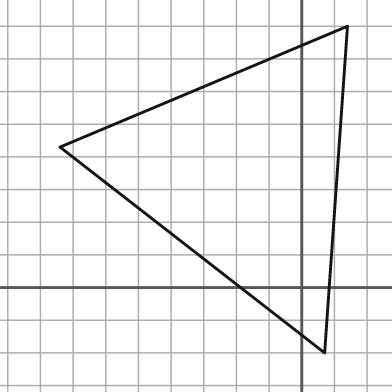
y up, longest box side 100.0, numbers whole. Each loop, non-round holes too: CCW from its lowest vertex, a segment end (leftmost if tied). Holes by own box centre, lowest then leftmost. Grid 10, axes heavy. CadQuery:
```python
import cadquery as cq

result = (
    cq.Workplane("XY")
    .moveTo(7.0, -20.0)
    .lineTo(14.0, 80.0)
    .lineTo(-74.0, 43.0)
    .close()
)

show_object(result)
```